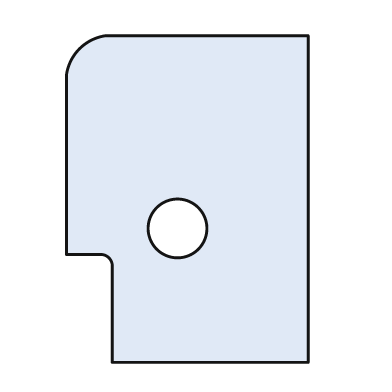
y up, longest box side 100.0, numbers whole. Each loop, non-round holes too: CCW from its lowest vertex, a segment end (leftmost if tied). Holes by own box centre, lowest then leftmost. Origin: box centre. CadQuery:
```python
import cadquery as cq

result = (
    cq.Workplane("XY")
    .moveTo(-23.0, -50.0)
    .lineTo(37.0, -50.0)
    .lineTo(37.0, 50.0)
    .lineTo(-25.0, 50.0)
    .threePointArc((-33.0, 46.0), (-37.0, 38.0))
    .lineTo(-37.0, -17.0)
    .lineTo(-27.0, -17.0)
    .threePointArc((-24.0, -18.0), (-23.0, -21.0))
    .close()
    .moveTo(-3.0, -9.0)
    .circle(9.0)
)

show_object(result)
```